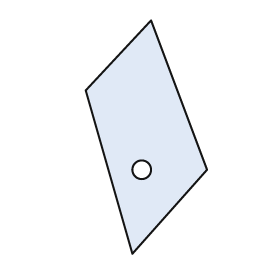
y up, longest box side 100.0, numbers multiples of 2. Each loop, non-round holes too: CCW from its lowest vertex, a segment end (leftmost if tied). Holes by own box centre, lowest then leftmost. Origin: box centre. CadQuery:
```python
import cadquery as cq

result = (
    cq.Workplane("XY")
    .moveTo(-6.0, -50.0)
    .lineTo(26.0, -14.0)
    .lineTo(2.0, 50.0)
    .lineTo(-26.0, 20.0)
    .close()
    .moveTo(-2.0, -14.0)
    .circle(4.0)
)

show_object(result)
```